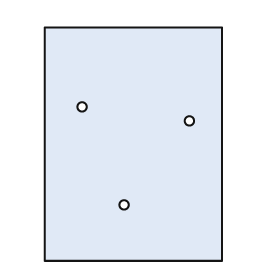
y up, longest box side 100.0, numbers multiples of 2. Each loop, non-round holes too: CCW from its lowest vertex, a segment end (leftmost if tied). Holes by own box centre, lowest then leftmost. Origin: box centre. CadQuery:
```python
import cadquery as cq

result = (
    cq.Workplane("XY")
    .moveTo(-38.0, -50.0)
    .lineTo(38.0, -50.0)
    .lineTo(38.0, 50.0)
    .lineTo(-38.0, 50.0)
    .close()
    .moveTo(-4.0, -26.0)
    .circle(2.0)
    .moveTo(24.0, 10.0)
    .circle(2.0)
    .moveTo(-22.0, 16.0)
    .circle(2.0)
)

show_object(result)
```